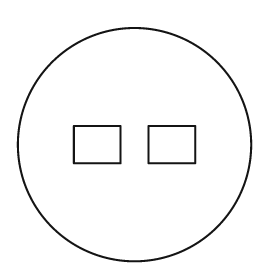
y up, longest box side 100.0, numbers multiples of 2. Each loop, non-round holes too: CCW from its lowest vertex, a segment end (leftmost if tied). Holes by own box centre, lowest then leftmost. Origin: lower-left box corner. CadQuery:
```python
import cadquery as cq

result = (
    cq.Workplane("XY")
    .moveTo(50.0, 50.0)
    .circle(50.0)
    .moveTo(24.0, 42.0)
    .lineTo(44.0, 42.0)
    .lineTo(44.0, 58.0)
    .lineTo(24.0, 58.0)
    .close()
    .moveTo(56.0, 42.0)
    .lineTo(76.0, 42.0)
    .lineTo(76.0, 58.0)
    .lineTo(56.0, 58.0)
    .close()
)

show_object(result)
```